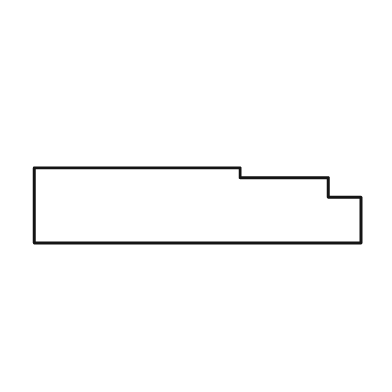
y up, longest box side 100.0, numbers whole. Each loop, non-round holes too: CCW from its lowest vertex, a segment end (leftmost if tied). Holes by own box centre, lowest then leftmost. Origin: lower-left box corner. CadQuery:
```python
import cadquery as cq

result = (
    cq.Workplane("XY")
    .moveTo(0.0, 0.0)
    .lineTo(100.0, 0.0)
    .lineTo(100.0, 14.0)
    .lineTo(90.0, 14.0)
    .lineTo(90.0, 20.0)
    .lineTo(63.0, 20.0)
    .lineTo(63.0, 23.0)
    .lineTo(0.0, 23.0)
    .close()
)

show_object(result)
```